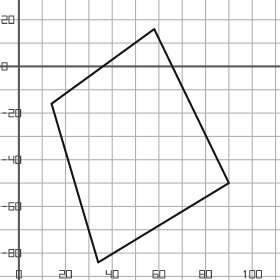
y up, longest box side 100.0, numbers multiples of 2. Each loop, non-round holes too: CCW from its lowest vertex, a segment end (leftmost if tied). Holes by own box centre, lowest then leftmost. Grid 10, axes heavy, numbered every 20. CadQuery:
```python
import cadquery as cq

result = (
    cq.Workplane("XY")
    .moveTo(34.0, -84.0)
    .lineTo(90.0, -50.0)
    .lineTo(58.0, 16.0)
    .lineTo(14.0, -16.0)
    .close()
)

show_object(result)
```